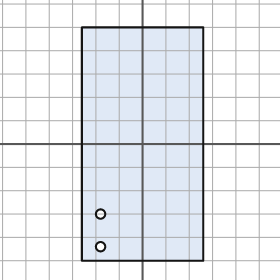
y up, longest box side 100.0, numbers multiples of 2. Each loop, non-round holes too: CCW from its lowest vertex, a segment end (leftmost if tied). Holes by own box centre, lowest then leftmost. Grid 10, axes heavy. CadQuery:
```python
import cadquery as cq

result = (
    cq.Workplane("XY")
    .moveTo(-26.0, -50.0)
    .lineTo(26.0, -50.0)
    .lineTo(26.0, 50.0)
    .lineTo(-26.0, 50.0)
    .close()
    .moveTo(-18.0, -44.0)
    .circle(2.0)
    .moveTo(-18.0, -30.0)
    .circle(2.0)
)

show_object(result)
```